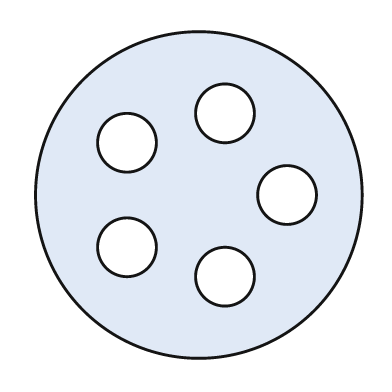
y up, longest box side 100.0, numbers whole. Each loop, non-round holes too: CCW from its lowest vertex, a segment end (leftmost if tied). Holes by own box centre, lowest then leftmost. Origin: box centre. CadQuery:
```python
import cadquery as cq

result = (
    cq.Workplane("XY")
    .moveTo(0.0, 0.0)
    .circle(50.0)
    .moveTo(8.0, -25.0)
    .circle(9.0)
    .moveTo(-22.0, -16.0)
    .circle(9.0)
    .moveTo(27.0, 0.0)
    .circle(9.0)
    .moveTo(-22.0, 16.0)
    .circle(9.0)
    .moveTo(8.0, 25.0)
    .circle(9.0)
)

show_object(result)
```